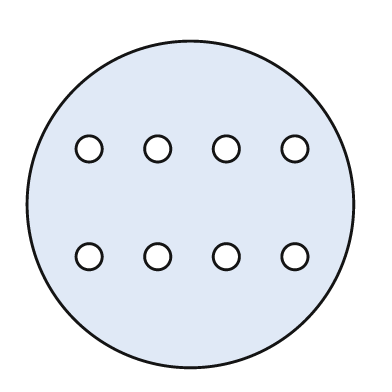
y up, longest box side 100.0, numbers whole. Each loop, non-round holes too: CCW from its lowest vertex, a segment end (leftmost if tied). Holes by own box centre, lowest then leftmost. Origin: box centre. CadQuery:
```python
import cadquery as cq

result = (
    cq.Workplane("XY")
    .moveTo(0.0, 0.0)
    .circle(50.0)
    .moveTo(-31.0, -16.0)
    .circle(4.0)
    .moveTo(-10.0, -16.0)
    .circle(4.0)
    .moveTo(11.0, -16.0)
    .circle(4.0)
    .moveTo(32.0, -16.0)
    .circle(4.0)
    .moveTo(-31.0, 17.0)
    .circle(4.0)
    .moveTo(-10.0, 17.0)
    .circle(4.0)
    .moveTo(11.0, 17.0)
    .circle(4.0)
    .moveTo(32.0, 17.0)
    .circle(4.0)
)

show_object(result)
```